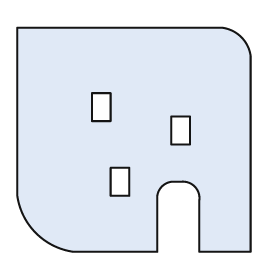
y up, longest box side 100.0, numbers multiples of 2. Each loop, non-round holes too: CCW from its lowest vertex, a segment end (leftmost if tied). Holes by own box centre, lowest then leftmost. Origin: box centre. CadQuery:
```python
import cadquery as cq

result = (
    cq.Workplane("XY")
    .moveTo(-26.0, -48.0)
    .lineTo(10.0, -48.0)
    .lineTo(10.0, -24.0)
    .threePointArc((12.0, -20.0), (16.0, -18.0))
    .lineTo(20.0, -18.0)
    .threePointArc((26.0, -20.0), (28.0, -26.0))
    .lineTo(28.0, -48.0)
    .lineTo(50.0, -48.0)
    .lineTo(50.0, 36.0)
    .threePointArc((46.0, 44.0), (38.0, 48.0))
    .lineTo(-50.0, 48.0)
    .lineTo(-50.0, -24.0)
    .threePointArc((-42.0, -40.0), (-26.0, -48.0))
    .close()
    .moveTo(-10.0, -24.0)
    .lineTo(-2.0, -24.0)
    .lineTo(-2.0, -12.0)
    .lineTo(-10.0, -12.0)
    .close()
    .moveTo(16.0, -2.0)
    .lineTo(24.0, -2.0)
    .lineTo(24.0, 10.0)
    .lineTo(16.0, 10.0)
    .close()
    .moveTo(-18.0, 8.0)
    .lineTo(-10.0, 8.0)
    .lineTo(-10.0, 20.0)
    .lineTo(-18.0, 20.0)
    .close()
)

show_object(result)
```